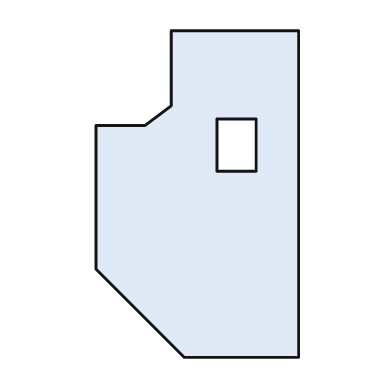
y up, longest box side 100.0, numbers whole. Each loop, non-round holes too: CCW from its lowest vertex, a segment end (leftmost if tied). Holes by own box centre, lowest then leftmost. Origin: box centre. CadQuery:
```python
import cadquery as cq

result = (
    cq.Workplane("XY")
    .moveTo(-4.0, -50.0)
    .lineTo(31.0, -50.0)
    .lineTo(31.0, 50.0)
    .lineTo(-8.0, 50.0)
    .lineTo(-8.0, 27.0)
    .lineTo(-16.0, 21.0)
    .lineTo(-31.0, 21.0)
    .lineTo(-31.0, -23.0)
    .close()
    .moveTo(6.0, 7.0)
    .lineTo(18.0, 7.0)
    .lineTo(18.0, 23.0)
    .lineTo(6.0, 23.0)
    .close()
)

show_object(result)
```